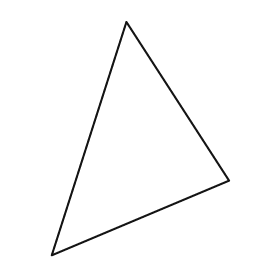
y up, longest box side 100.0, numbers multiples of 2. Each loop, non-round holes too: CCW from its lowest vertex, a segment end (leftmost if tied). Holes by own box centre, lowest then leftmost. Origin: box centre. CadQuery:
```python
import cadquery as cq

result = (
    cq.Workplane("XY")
    .moveTo(-38.0, -50.0)
    .lineTo(38.0, -18.0)
    .lineTo(-6.0, 50.0)
    .close()
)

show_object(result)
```